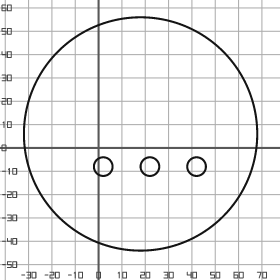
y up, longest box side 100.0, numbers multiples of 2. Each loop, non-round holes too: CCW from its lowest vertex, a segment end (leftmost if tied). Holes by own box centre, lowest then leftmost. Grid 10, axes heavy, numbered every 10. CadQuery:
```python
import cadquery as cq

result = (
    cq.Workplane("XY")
    .moveTo(18.0, 6.0)
    .circle(50.0)
    .moveTo(2.0, -8.0)
    .circle(4.0)
    .moveTo(22.0, -8.0)
    .circle(4.0)
    .moveTo(42.0, -8.0)
    .circle(4.0)
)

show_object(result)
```